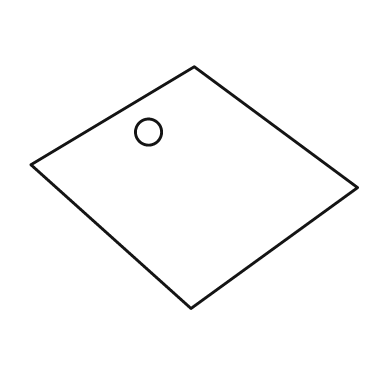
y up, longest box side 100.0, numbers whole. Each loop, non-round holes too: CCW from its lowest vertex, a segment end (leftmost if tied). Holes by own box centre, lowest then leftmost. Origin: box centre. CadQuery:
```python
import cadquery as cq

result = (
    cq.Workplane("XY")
    .moveTo(-1.0, -37.0)
    .lineTo(50.0, 0.0)
    .lineTo(0.0, 37.0)
    .lineTo(-50.0, 7.0)
    .close()
    .moveTo(-14.0, 17.0)
    .circle(4.0)
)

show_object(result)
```